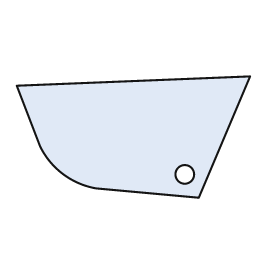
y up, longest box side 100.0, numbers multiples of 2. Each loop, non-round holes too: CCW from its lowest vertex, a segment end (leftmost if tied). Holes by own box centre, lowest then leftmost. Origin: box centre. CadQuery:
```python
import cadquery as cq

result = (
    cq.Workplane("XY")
    .moveTo(28.0, -26.0)
    .lineTo(50.0, 26.0)
    .lineTo(-50.0, 22.0)
    .lineTo(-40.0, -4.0)
    .threePointArc((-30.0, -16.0), (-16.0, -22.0))
    .close()
    .moveTo(22.0, -16.0)
    .circle(4.0)
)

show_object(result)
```